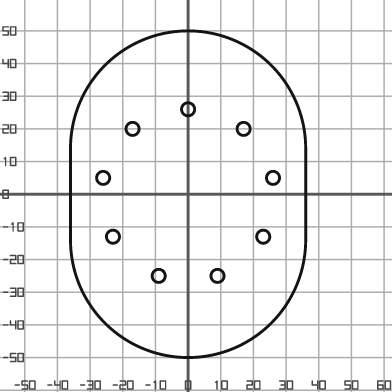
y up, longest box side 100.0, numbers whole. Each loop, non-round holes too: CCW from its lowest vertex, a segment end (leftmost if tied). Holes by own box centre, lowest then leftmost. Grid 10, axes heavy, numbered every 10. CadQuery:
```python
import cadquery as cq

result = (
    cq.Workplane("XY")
    .moveTo(-36.0, -14.0)
    .threePointArc((0.0, -50.0), (36.0, -14.0))
    .lineTo(36.0, 14.0)
    .threePointArc((0.0, 50.0), (-36.0, 14.0))
    .close()
    .moveTo(-9.0, -25.0)
    .circle(2.0)
    .moveTo(9.0, -25.0)
    .circle(2.0)
    .moveTo(-23.0, -13.0)
    .circle(2.0)
    .moveTo(23.0, -13.0)
    .circle(2.0)
    .moveTo(-26.0, 5.0)
    .circle(2.0)
    .moveTo(26.0, 5.0)
    .circle(2.0)
    .moveTo(-17.0, 20.0)
    .circle(2.0)
    .moveTo(17.0, 20.0)
    .circle(2.0)
    .moveTo(0.0, 26.0)
    .circle(2.0)
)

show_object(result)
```